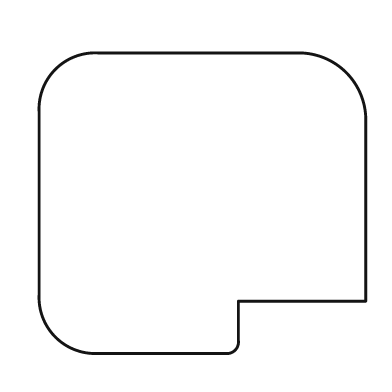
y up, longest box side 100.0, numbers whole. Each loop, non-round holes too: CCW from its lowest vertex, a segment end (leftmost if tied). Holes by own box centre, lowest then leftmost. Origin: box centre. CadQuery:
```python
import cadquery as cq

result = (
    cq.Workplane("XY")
    .moveTo(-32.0, -46.0)
    .lineTo(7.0, -46.0)
    .threePointArc((10.0, -45.0), (11.0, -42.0))
    .lineTo(11.0, -30.0)
    .lineTo(50.0, -30.0)
    .lineTo(50.0, 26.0)
    .threePointArc((44.0, 40.0), (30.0, 46.0))
    .lineTo(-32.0, 46.0)
    .threePointArc((-45.0, 41.0), (-50.0, 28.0))
    .lineTo(-50.0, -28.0)
    .threePointArc((-45.0, -41.0), (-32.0, -46.0))
    .close()
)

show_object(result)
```